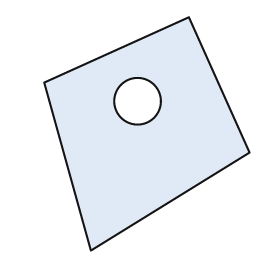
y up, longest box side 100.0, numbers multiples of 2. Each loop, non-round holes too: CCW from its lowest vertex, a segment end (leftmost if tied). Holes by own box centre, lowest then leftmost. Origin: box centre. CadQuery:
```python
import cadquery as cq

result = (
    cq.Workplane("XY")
    .moveTo(-24.0, -50.0)
    .lineTo(44.0, -8.0)
    .lineTo(18.0, 50.0)
    .lineTo(-44.0, 22.0)
    .close()
    .moveTo(-4.0, 14.0)
    .circle(10.0)
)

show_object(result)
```